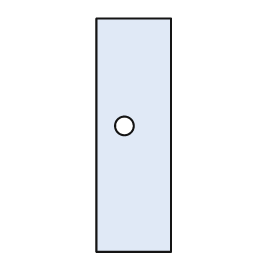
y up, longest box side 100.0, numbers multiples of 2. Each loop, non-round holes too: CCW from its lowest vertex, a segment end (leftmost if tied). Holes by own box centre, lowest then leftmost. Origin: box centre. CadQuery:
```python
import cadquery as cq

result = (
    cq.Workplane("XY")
    .moveTo(-16.0, -50.0)
    .lineTo(16.0, -50.0)
    .lineTo(16.0, 50.0)
    .lineTo(-16.0, 50.0)
    .close()
    .moveTo(-4.0, 4.0)
    .circle(4.0)
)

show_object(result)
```